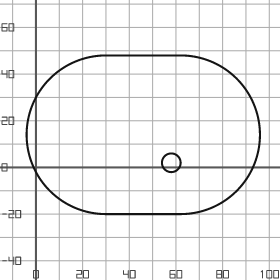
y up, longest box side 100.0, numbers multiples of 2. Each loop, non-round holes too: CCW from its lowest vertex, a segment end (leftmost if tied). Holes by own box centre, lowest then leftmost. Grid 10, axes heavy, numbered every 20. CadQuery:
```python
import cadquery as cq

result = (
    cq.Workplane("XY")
    .moveTo(30.0, -20.0)
    .lineTo(62.0, -20.0)
    .threePointArc((96.0, 14.0), (62.0, 48.0))
    .lineTo(30.0, 48.0)
    .threePointArc((-4.0, 14.0), (30.0, -20.0))
    .close()
    .moveTo(58.0, 2.0)
    .circle(4.0)
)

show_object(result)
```